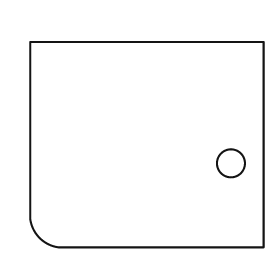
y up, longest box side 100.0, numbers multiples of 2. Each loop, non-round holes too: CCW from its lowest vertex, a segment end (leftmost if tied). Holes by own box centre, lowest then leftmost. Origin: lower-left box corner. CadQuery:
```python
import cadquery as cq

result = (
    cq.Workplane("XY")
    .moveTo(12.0, 0.0)
    .lineTo(100.0, 0.0)
    .lineTo(100.0, 88.0)
    .lineTo(0.0, 88.0)
    .lineTo(0.0, 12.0)
    .threePointArc((4.0, 4.0), (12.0, 0.0))
    .close()
    .moveTo(86.0, 36.0)
    .circle(6.0)
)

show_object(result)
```